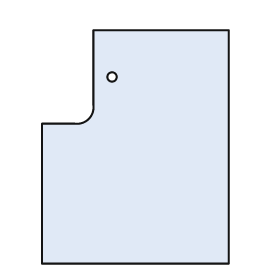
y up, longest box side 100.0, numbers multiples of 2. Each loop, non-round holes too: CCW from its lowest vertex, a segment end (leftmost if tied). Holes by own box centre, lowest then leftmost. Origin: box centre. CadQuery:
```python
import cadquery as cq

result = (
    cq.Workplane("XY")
    .moveTo(-40.0, -50.0)
    .lineTo(40.0, -50.0)
    .lineTo(40.0, 50.0)
    .lineTo(-18.0, 50.0)
    .lineTo(-18.0, 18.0)
    .threePointArc((-20.0, 12.0), (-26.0, 10.0))
    .lineTo(-40.0, 10.0)
    .close()
    .moveTo(-10.0, 30.0)
    .circle(2.0)
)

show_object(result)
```